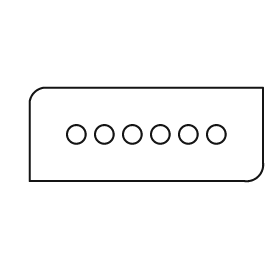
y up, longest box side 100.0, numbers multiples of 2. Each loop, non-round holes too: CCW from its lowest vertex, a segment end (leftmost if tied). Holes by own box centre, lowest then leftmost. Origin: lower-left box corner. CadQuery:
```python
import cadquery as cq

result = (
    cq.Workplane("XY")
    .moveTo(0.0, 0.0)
    .lineTo(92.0, 0.0)
    .threePointArc((98.0, 2.0), (100.0, 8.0))
    .lineTo(100.0, 40.0)
    .lineTo(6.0, 40.0)
    .threePointArc((2.0, 38.0), (0.0, 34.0))
    .close()
    .moveTo(20.0, 20.0)
    .circle(4.0)
    .moveTo(32.0, 20.0)
    .circle(4.0)
    .moveTo(44.0, 20.0)
    .circle(4.0)
    .moveTo(56.0, 20.0)
    .circle(4.0)
    .moveTo(68.0, 20.0)
    .circle(4.0)
    .moveTo(80.0, 20.0)
    .circle(4.0)
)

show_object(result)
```